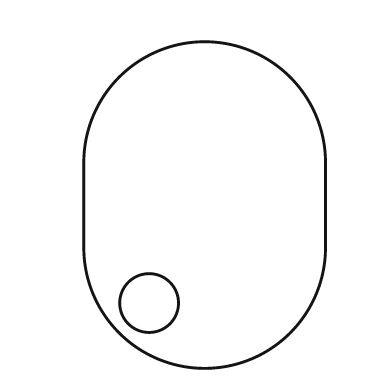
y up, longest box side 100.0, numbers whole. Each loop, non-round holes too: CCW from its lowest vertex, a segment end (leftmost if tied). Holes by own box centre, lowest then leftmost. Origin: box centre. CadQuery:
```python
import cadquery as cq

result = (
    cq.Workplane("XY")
    .moveTo(-37.0, -13.0)
    .threePointArc((0.0, -50.0), (37.0, -13.0))
    .lineTo(37.0, 13.0)
    .threePointArc((0.0, 50.0), (-37.0, 13.0))
    .close()
    .moveTo(-17.0, -30.0)
    .circle(9.0)
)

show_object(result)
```